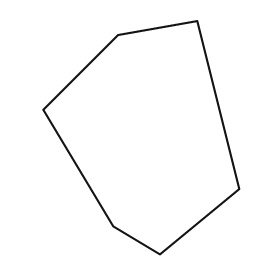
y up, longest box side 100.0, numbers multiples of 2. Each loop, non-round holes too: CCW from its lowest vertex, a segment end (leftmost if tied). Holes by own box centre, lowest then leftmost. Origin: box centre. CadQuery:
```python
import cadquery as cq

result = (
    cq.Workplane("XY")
    .moveTo(8.0, -50.0)
    .lineTo(42.0, -22.0)
    .lineTo(24.0, 50.0)
    .lineTo(-10.0, 44.0)
    .lineTo(-42.0, 12.0)
    .lineTo(-12.0, -38.0)
    .close()
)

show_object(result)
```